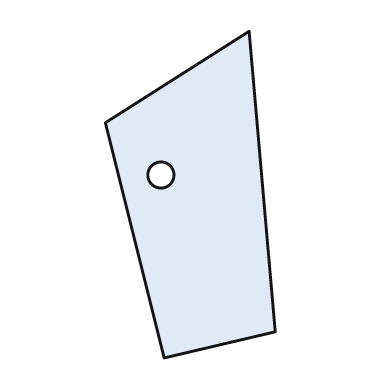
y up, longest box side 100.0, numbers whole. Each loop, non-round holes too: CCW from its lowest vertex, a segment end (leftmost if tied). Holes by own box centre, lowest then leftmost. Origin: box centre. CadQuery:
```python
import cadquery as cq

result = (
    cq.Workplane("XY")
    .moveTo(-8.0, -50.0)
    .lineTo(26.0, -42.0)
    .lineTo(18.0, 50.0)
    .lineTo(-26.0, 22.0)
    .close()
    .moveTo(-9.0, 6.0)
    .circle(4.0)
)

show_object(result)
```